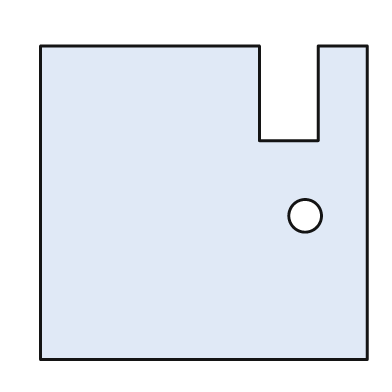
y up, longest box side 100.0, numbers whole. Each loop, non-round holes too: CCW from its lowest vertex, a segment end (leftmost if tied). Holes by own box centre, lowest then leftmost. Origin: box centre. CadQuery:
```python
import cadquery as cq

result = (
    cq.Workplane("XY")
    .moveTo(-50.0, -48.0)
    .lineTo(50.0, -48.0)
    .lineTo(50.0, 48.0)
    .lineTo(35.0, 48.0)
    .lineTo(35.0, 19.0)
    .lineTo(17.0, 19.0)
    .lineTo(17.0, 48.0)
    .lineTo(-50.0, 48.0)
    .close()
    .moveTo(31.0, -4.0)
    .circle(5.0)
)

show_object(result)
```